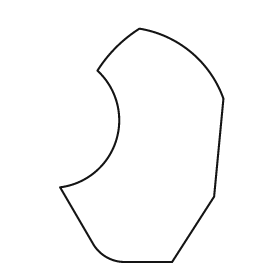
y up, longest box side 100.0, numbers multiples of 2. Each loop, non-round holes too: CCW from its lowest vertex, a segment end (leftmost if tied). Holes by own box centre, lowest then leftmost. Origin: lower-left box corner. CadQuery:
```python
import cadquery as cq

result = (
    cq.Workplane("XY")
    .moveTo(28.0, 0.0)
    .lineTo(48.0, 0.0)
    .lineTo(66.0, 28.0)
    .lineTo(70.0, 70.0)
    .threePointArc((56.0, 90.0), (34.0, 100.0))
    .threePointArc((24.0, 92.0), (16.0, 82.0))
    .threePointArc((24.0, 52.0), (0.0, 32.0))
    .lineTo(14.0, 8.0)
    .threePointArc((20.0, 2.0), (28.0, 0.0))
    .close()
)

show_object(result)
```